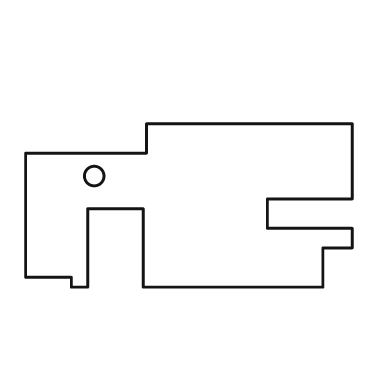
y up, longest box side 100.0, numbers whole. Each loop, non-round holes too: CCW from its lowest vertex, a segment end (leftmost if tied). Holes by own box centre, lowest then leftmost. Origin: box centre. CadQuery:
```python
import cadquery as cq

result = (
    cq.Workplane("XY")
    .moveTo(-36.0, -25.0)
    .lineTo(-31.0, -25.0)
    .lineTo(-31.0, -1.0)
    .lineTo(-14.0, -1.0)
    .lineTo(-14.0, -25.0)
    .lineTo(41.0, -25.0)
    .lineTo(41.0, -13.0)
    .lineTo(50.0, -13.0)
    .lineTo(50.0, -7.0)
    .lineTo(24.0, -7.0)
    .lineTo(24.0, 2.0)
    .lineTo(50.0, 2.0)
    .lineTo(50.0, 25.0)
    .lineTo(-13.0, 25.0)
    .lineTo(-13.0, 16.0)
    .lineTo(-50.0, 16.0)
    .lineTo(-50.0, -22.0)
    .lineTo(-36.0, -22.0)
    .close()
    .moveTo(-29.0, 9.0)
    .circle(3.0)
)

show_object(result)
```